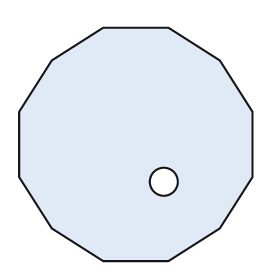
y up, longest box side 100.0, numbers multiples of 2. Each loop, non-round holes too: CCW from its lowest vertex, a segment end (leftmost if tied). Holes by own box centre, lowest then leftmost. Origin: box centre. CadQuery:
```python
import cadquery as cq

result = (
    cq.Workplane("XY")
    .moveTo(-14.0, -50.0)
    .lineTo(14.0, -50.0)
    .lineTo(36.0, -36.0)
    .lineTo(50.0, -14.0)
    .lineTo(50.0, 14.0)
    .lineTo(36.0, 36.0)
    .lineTo(14.0, 50.0)
    .lineTo(-14.0, 50.0)
    .lineTo(-36.0, 36.0)
    .lineTo(-50.0, 14.0)
    .lineTo(-50.0, -14.0)
    .lineTo(-36.0, -36.0)
    .close()
    .moveTo(12.0, -16.0)
    .circle(6.0)
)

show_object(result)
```